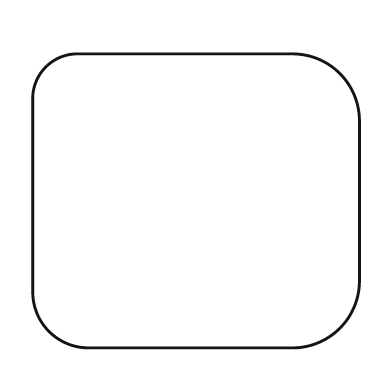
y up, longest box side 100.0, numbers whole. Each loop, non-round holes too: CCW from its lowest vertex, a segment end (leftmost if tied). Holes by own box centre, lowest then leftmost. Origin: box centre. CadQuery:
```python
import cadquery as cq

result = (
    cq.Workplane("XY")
    .moveTo(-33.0, -45.0)
    .lineTo(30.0, -45.0)
    .threePointArc((44.0, -39.0), (50.0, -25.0))
    .lineTo(50.0, 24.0)
    .threePointArc((44.0, 39.0), (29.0, 45.0))
    .lineTo(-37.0, 45.0)
    .threePointArc((-46.0, 41.0), (-50.0, 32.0))
    .lineTo(-50.0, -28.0)
    .threePointArc((-45.0, -40.0), (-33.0, -45.0))
    .close()
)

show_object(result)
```